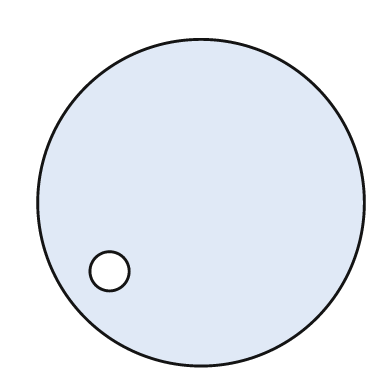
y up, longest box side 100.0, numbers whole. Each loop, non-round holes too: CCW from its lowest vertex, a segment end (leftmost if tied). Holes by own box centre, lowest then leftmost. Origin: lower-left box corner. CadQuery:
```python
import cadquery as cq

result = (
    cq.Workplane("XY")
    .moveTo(50.0, 50.0)
    .circle(50.0)
    .moveTo(22.0, 29.0)
    .circle(6.0)
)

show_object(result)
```